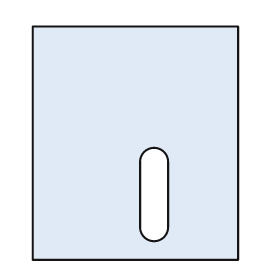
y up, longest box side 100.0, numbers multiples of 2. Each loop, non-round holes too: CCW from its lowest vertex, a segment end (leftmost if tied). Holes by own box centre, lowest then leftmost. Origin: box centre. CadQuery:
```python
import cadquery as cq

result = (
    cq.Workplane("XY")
    .moveTo(-44.0, -50.0)
    .lineTo(44.0, -50.0)
    .lineTo(44.0, 50.0)
    .lineTo(-44.0, 50.0)
    .close()
    .moveTo(2.0, -36.0)
    .threePointArc((8.0, -42.0), (14.0, -36.0))
    .lineTo(14.0, -8.0)
    .threePointArc((8.0, -2.0), (2.0, -8.0))
    .close()
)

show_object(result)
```